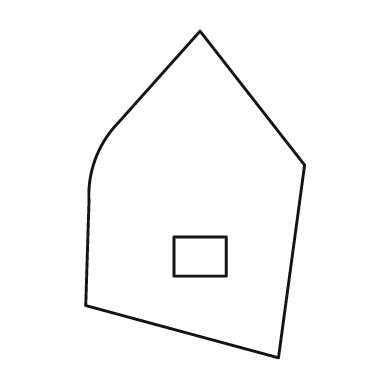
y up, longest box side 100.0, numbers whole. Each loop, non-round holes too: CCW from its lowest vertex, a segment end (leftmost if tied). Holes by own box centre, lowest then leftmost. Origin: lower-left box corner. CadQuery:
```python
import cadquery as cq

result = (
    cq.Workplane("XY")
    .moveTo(59.0, 0.0)
    .lineTo(67.0, 59.0)
    .lineTo(35.0, 100.0)
    .lineTo(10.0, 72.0)
    .threePointArc((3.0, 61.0), (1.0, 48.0))
    .lineTo(0.0, 16.0)
    .close()
    .moveTo(27.0, 25.0)
    .lineTo(43.0, 25.0)
    .lineTo(43.0, 37.0)
    .lineTo(27.0, 37.0)
    .close()
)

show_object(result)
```